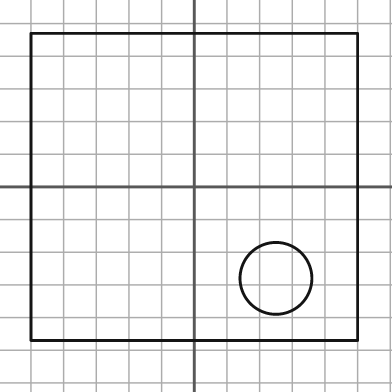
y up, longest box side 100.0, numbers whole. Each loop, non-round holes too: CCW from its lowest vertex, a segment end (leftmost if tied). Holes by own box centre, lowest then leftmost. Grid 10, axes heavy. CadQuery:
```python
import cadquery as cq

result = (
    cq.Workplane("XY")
    .moveTo(-50.0, -47.0)
    .lineTo(50.0, -47.0)
    .lineTo(50.0, 47.0)
    .lineTo(-50.0, 47.0)
    .close()
    .moveTo(25.0, -28.0)
    .circle(11.0)
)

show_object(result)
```